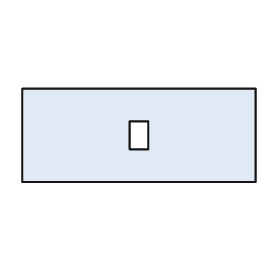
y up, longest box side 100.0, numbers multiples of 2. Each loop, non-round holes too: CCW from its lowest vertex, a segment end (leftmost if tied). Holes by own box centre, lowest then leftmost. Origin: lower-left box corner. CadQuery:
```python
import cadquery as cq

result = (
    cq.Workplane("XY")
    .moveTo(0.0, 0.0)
    .lineTo(100.0, 0.0)
    .lineTo(100.0, 40.0)
    .lineTo(0.0, 40.0)
    .close()
    .moveTo(46.0, 14.0)
    .lineTo(54.0, 14.0)
    .lineTo(54.0, 26.0)
    .lineTo(46.0, 26.0)
    .close()
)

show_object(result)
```